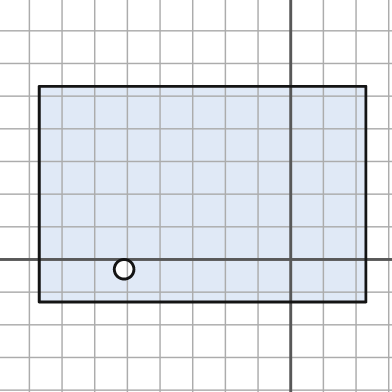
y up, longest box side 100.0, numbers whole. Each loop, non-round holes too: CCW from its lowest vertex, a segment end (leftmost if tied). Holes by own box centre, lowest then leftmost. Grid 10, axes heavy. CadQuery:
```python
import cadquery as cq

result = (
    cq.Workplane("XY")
    .moveTo(-77.0, -13.0)
    .lineTo(23.0, -13.0)
    .lineTo(23.0, 53.0)
    .lineTo(-77.0, 53.0)
    .close()
    .moveTo(-51.0, -3.0)
    .circle(3.0)
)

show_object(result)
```